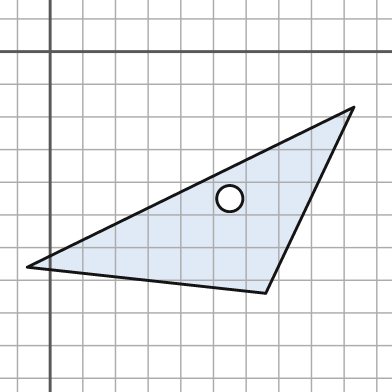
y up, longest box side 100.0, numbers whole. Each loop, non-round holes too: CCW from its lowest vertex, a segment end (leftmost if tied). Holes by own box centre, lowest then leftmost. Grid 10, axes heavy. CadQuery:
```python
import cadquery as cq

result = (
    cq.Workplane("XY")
    .moveTo(66.0, -74.0)
    .lineTo(93.0, -17.0)
    .lineTo(-7.0, -66.0)
    .close()
    .moveTo(55.0, -45.0)
    .circle(4.0)
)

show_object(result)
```